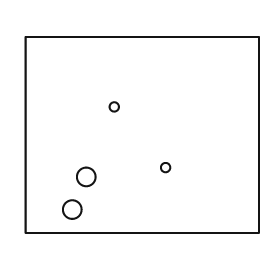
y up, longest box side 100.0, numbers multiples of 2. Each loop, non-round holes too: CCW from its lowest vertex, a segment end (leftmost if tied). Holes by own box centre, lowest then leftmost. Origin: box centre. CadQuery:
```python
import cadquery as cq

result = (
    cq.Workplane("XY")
    .moveTo(-50.0, -42.0)
    .lineTo(50.0, -42.0)
    .lineTo(50.0, 42.0)
    .lineTo(-50.0, 42.0)
    .close()
    .moveTo(-30.0, -32.0)
    .circle(4.0)
    .moveTo(-24.0, -18.0)
    .circle(4.0)
    .moveTo(10.0, -14.0)
    .circle(2.0)
    .moveTo(-12.0, 12.0)
    .circle(2.0)
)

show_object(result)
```